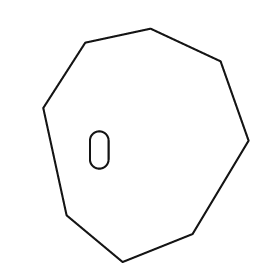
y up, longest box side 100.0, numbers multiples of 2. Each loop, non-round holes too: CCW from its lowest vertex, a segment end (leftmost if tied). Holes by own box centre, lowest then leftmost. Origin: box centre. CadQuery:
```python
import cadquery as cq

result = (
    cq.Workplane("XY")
    .moveTo(-10.0, -50.0)
    .lineTo(20.0, -38.0)
    .lineTo(44.0, 2.0)
    .lineTo(32.0, 36.0)
    .lineTo(2.0, 50.0)
    .lineTo(-26.0, 44.0)
    .lineTo(-44.0, 16.0)
    .lineTo(-34.0, -30.0)
    .close()
    .moveTo(-24.0, -6.0)
    .threePointArc((-20.0, -10.0), (-16.0, -6.0))
    .lineTo(-16.0, 2.0)
    .threePointArc((-20.0, 6.0), (-24.0, 2.0))
    .close()
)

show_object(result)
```